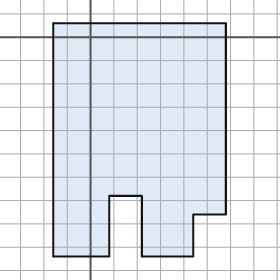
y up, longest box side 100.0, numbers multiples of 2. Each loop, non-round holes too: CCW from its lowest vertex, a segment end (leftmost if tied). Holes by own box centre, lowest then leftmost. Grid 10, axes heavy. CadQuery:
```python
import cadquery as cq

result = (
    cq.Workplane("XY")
    .moveTo(-16.0, -94.0)
    .lineTo(8.0, -94.0)
    .lineTo(8.0, -68.0)
    .lineTo(22.0, -68.0)
    .lineTo(22.0, -94.0)
    .lineTo(44.0, -94.0)
    .lineTo(44.0, -76.0)
    .lineTo(58.0, -76.0)
    .lineTo(58.0, 6.0)
    .lineTo(-16.0, 6.0)
    .close()
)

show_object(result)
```